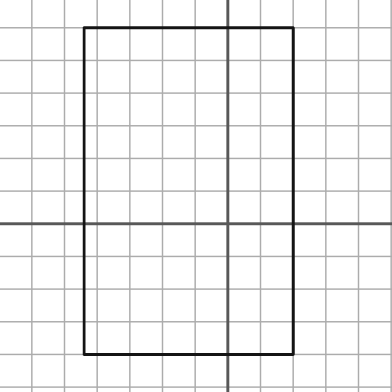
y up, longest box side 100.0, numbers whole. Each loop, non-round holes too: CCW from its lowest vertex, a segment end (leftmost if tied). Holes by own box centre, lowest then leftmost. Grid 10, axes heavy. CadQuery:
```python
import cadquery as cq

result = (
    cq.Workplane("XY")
    .moveTo(-44.0, -40.0)
    .lineTo(20.0, -40.0)
    .lineTo(20.0, 60.0)
    .lineTo(-44.0, 60.0)
    .close()
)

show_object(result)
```